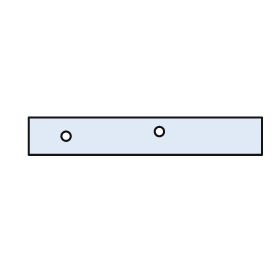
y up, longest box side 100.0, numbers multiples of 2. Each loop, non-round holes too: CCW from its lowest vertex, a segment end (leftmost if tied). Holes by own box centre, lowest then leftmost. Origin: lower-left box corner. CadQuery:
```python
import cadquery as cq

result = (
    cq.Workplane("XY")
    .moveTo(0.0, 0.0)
    .lineTo(100.0, 0.0)
    .lineTo(100.0, 16.0)
    .lineTo(0.0, 16.0)
    .close()
    .moveTo(16.0, 8.0)
    .circle(2.0)
    .moveTo(56.0, 10.0)
    .circle(2.0)
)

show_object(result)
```